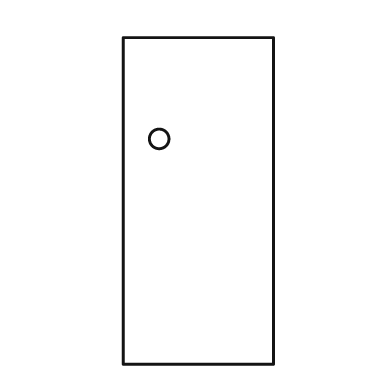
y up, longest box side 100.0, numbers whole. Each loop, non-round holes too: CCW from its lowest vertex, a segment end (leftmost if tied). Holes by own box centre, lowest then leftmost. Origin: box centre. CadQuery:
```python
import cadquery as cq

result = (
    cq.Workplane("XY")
    .moveTo(-23.0, -50.0)
    .lineTo(23.0, -50.0)
    .lineTo(23.0, 50.0)
    .lineTo(-23.0, 50.0)
    .close()
    .moveTo(-12.0, 19.0)
    .circle(3.0)
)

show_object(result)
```